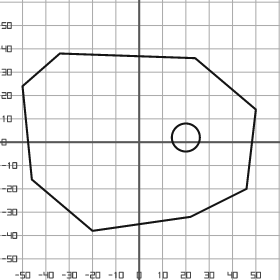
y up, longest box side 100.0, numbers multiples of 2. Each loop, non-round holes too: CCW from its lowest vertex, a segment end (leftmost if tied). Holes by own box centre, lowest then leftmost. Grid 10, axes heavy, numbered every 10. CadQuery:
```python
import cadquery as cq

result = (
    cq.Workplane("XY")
    .moveTo(-20.0, -38.0)
    .lineTo(22.0, -32.0)
    .lineTo(46.0, -20.0)
    .lineTo(50.0, 14.0)
    .lineTo(24.0, 36.0)
    .lineTo(-34.0, 38.0)
    .lineTo(-50.0, 24.0)
    .lineTo(-46.0, -16.0)
    .close()
    .moveTo(20.0, 2.0)
    .circle(6.0)
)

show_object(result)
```